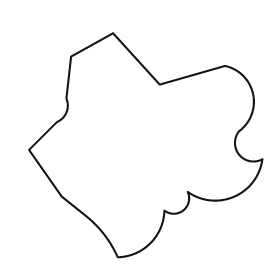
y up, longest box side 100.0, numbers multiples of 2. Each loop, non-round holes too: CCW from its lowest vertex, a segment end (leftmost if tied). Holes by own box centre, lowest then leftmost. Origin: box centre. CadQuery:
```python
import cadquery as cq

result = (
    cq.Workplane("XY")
    .moveTo(-12.0, -48.0)
    .threePointArc((2.0, -42.0), (8.0, -28.0))
    .threePointArc((16.0, -28.0), (18.0, -20.0))
    .threePointArc((38.0, -22.0), (50.0, -6.0))
    .threePointArc((40.0, -4.0), (40.0, 6.0))
    .threePointArc((46.0, 22.0), (34.0, 34.0))
    .lineTo(6.0, 26.0)
    .lineTo(-14.0, 48.0)
    .lineTo(-32.0, 38.0)
    .lineTo(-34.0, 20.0)
    .threePointArc((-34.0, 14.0), (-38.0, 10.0))
    .lineTo(-50.0, -2.0)
    .lineTo(-36.0, -22.0)
    .lineTo(-26.0, -30.0)
    .threePointArc((-18.0, -38.0), (-12.0, -48.0))
    .close()
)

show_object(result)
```